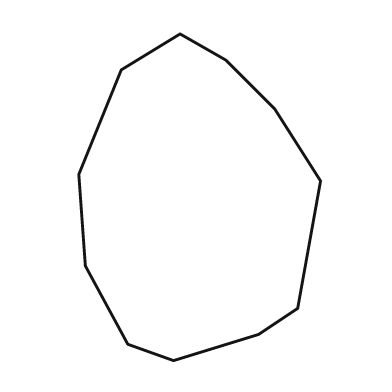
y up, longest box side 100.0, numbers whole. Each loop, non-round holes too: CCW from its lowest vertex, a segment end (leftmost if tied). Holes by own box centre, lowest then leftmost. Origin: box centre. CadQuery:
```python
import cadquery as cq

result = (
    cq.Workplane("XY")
    .moveTo(-8.0, -50.0)
    .lineTo(18.0, -42.0)
    .lineTo(30.0, -34.0)
    .lineTo(37.0, 5.0)
    .lineTo(23.0, 27.0)
    .lineTo(8.0, 42.0)
    .lineTo(-6.0, 50.0)
    .lineTo(-24.0, 39.0)
    .lineTo(-37.0, 7.0)
    .lineTo(-35.0, -21.0)
    .lineTo(-22.0, -45.0)
    .close()
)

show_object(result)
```